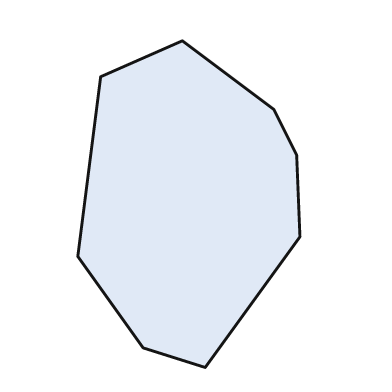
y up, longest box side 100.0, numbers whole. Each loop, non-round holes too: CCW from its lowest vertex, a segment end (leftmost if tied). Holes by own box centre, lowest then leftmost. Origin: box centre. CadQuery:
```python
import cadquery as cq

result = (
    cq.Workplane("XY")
    .moveTo(5.0, -50.0)
    .lineTo(34.0, -10.0)
    .lineTo(33.0, 15.0)
    .lineTo(26.0, 29.0)
    .lineTo(-2.0, 50.0)
    .lineTo(-27.0, 39.0)
    .lineTo(-34.0, -16.0)
    .lineTo(-14.0, -44.0)
    .close()
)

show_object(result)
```